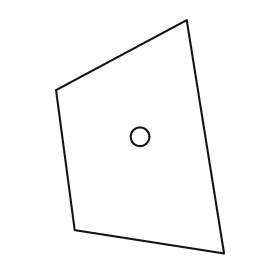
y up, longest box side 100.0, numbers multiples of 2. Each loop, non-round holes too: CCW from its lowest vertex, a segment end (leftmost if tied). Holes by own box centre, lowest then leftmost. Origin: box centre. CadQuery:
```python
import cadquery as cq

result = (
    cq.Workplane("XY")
    .moveTo(36.0, -50.0)
    .lineTo(20.0, 50.0)
    .lineTo(-36.0, 20.0)
    .lineTo(-28.0, -40.0)
    .close()
    .moveTo(0.0, 0.0)
    .circle(4.0)
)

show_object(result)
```